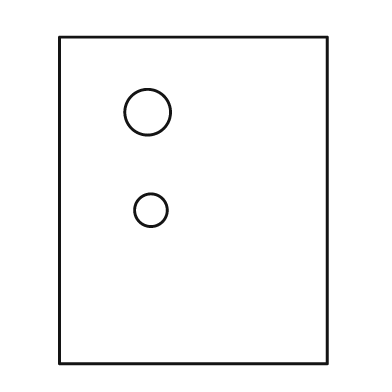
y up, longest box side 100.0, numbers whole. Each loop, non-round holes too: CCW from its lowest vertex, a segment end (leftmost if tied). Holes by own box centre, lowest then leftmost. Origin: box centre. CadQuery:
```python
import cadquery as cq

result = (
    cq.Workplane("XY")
    .moveTo(-41.0, -50.0)
    .lineTo(41.0, -50.0)
    .lineTo(41.0, 50.0)
    .lineTo(-41.0, 50.0)
    .close()
    .moveTo(-13.0, -3.0)
    .circle(5.0)
    .moveTo(-14.0, 27.0)
    .circle(7.0)
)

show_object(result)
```